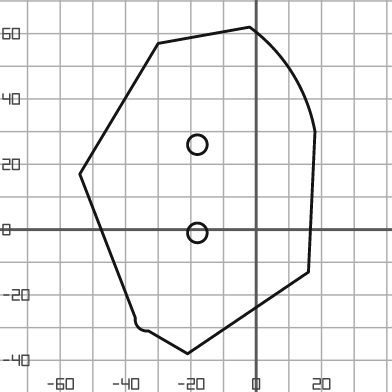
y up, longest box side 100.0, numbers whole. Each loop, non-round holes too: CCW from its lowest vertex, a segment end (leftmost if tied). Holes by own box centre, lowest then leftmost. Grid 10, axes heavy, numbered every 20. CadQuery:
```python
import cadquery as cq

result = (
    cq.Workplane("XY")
    .moveTo(-21.0, -38.0)
    .lineTo(16.0, -13.0)
    .lineTo(18.0, 30.0)
    .threePointArc((11.0, 48.0), (-2.0, 62.0))
    .lineTo(-30.0, 57.0)
    .lineTo(-54.0, 17.0)
    .lineTo(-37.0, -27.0)
    .threePointArc((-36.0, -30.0), (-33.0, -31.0))
    .close()
    .moveTo(-18.0, -1.0)
    .circle(3.0)
    .moveTo(-18.0, 26.0)
    .circle(3.0)
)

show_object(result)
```